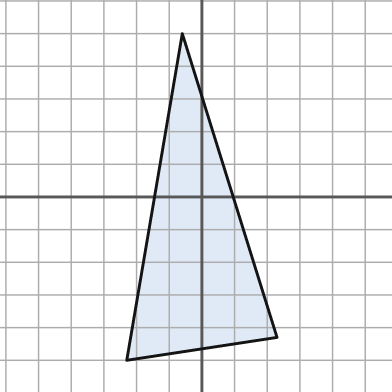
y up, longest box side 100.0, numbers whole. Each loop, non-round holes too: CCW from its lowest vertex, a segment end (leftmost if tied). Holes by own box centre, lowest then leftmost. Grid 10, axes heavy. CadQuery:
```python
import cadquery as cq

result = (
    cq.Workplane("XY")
    .moveTo(-23.0, -50.0)
    .lineTo(23.0, -43.0)
    .lineTo(-6.0, 50.0)
    .close()
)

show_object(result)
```